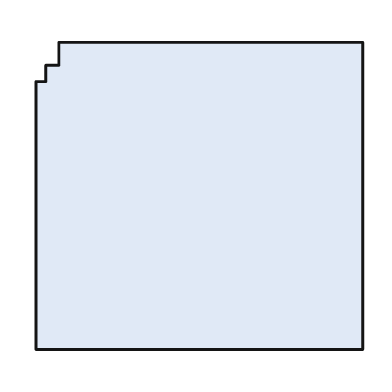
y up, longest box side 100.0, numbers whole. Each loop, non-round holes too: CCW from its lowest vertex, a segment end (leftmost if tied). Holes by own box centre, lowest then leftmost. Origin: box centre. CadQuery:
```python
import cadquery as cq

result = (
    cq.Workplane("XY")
    .moveTo(-50.0, -47.0)
    .lineTo(50.0, -47.0)
    .lineTo(50.0, 47.0)
    .lineTo(-43.0, 47.0)
    .lineTo(-43.0, 40.0)
    .lineTo(-47.0, 40.0)
    .lineTo(-47.0, 35.0)
    .lineTo(-50.0, 35.0)
    .close()
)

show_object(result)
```